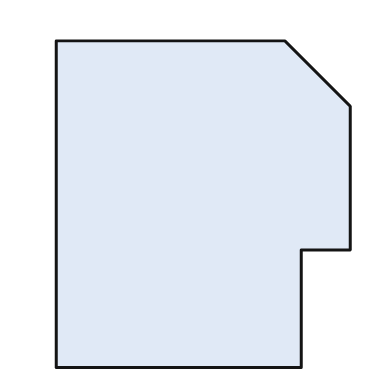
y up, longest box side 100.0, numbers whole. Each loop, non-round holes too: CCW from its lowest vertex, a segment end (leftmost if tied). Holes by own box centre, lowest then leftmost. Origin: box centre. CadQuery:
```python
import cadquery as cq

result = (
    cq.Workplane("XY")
    .moveTo(-45.0, -50.0)
    .lineTo(30.0, -50.0)
    .lineTo(30.0, -14.0)
    .lineTo(45.0, -14.0)
    .lineTo(45.0, 30.0)
    .lineTo(25.0, 50.0)
    .lineTo(-45.0, 50.0)
    .close()
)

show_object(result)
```